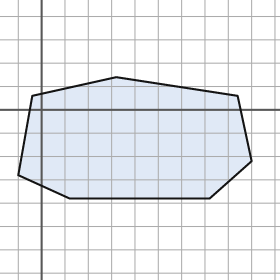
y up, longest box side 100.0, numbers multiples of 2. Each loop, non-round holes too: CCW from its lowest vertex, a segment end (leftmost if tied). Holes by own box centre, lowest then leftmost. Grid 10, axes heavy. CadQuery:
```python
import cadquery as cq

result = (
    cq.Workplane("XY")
    .moveTo(12.0, -38.0)
    .lineTo(72.0, -38.0)
    .lineTo(90.0, -22.0)
    .lineTo(84.0, 6.0)
    .lineTo(32.0, 14.0)
    .lineTo(-4.0, 6.0)
    .lineTo(-10.0, -28.0)
    .close()
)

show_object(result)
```